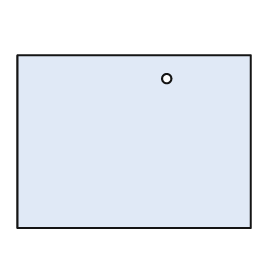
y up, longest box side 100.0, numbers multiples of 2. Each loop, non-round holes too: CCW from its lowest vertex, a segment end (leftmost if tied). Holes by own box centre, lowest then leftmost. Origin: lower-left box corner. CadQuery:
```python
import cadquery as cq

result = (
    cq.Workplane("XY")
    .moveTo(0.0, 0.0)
    .lineTo(100.0, 0.0)
    .lineTo(100.0, 74.0)
    .lineTo(0.0, 74.0)
    .close()
    .moveTo(64.0, 64.0)
    .circle(2.0)
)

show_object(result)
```